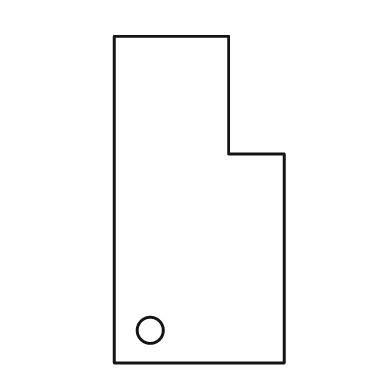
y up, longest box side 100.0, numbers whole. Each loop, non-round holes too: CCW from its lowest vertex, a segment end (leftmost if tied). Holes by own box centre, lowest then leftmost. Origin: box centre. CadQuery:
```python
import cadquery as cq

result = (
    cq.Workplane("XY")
    .moveTo(-26.0, -50.0)
    .lineTo(26.0, -50.0)
    .lineTo(26.0, 14.0)
    .lineTo(9.0, 14.0)
    .lineTo(9.0, 50.0)
    .lineTo(-26.0, 50.0)
    .close()
    .moveTo(-15.0, -40.0)
    .circle(4.0)
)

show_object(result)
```